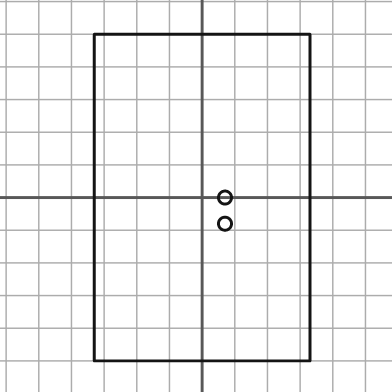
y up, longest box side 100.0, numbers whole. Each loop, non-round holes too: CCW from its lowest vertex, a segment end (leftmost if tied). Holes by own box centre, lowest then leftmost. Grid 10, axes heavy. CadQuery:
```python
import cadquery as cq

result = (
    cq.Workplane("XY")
    .moveTo(-33.0, -50.0)
    .lineTo(33.0, -50.0)
    .lineTo(33.0, 50.0)
    .lineTo(-33.0, 50.0)
    .close()
    .moveTo(7.0, -8.0)
    .circle(2.0)
    .moveTo(7.0, 0.0)
    .circle(2.0)
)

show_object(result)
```